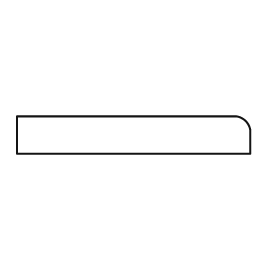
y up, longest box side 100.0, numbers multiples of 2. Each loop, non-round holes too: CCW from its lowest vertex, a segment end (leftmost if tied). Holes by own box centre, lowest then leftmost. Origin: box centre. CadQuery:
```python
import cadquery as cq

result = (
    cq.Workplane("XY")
    .moveTo(-50.0, -8.0)
    .lineTo(50.0, -8.0)
    .lineTo(50.0, 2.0)
    .threePointArc((48.0, 6.0), (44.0, 8.0))
    .lineTo(-50.0, 8.0)
    .close()
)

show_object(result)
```